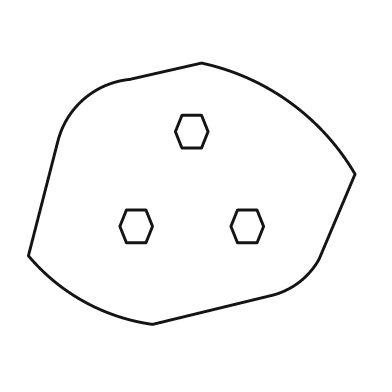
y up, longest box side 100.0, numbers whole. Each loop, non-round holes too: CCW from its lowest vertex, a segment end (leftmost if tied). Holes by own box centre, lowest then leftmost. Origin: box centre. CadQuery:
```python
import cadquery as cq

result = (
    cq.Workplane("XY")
    .moveTo(-12.0, -40.0)
    .lineTo(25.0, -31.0)
    .threePointArc((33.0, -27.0), (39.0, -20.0))
    .lineTo(50.0, 6.0)
    .threePointArc((30.0, 28.0), (3.0, 40.0))
    .lineTo(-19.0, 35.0)
    .threePointArc((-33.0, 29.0), (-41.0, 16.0))
    .lineTo(-50.0, -19.0)
    .threePointArc((-33.0, -33.0), (-12.0, -40.0))
    .close()
    .moveTo(-20.0, -15.0)
    .lineTo(-14.0, -15.0)
    .lineTo(-12.0, -10.0)
    .lineTo(-14.0, -5.0)
    .lineTo(-20.0, -5.0)
    .lineTo(-22.0, -10.0)
    .close()
    .moveTo(14.0, -15.0)
    .lineTo(20.0, -15.0)
    .lineTo(22.0, -10.0)
    .lineTo(20.0, -5.0)
    .lineTo(14.0, -5.0)
    .lineTo(12.0, -10.0)
    .close()
    .moveTo(-3.0, 14.0)
    .lineTo(3.0, 14.0)
    .lineTo(5.0, 19.0)
    .lineTo(3.0, 24.0)
    .lineTo(-3.0, 24.0)
    .lineTo(-5.0, 19.0)
    .close()
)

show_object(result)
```